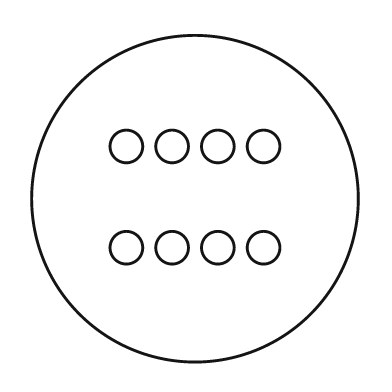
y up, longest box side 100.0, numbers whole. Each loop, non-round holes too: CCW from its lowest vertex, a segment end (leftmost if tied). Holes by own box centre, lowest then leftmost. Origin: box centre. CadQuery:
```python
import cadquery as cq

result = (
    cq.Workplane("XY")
    .moveTo(0.0, 0.0)
    .circle(50.0)
    .moveTo(-21.0, -15.0)
    .circle(5.0)
    .moveTo(-7.0, -15.0)
    .circle(5.0)
    .moveTo(7.0, -15.0)
    .circle(5.0)
    .moveTo(21.0, -15.0)
    .circle(5.0)
    .moveTo(-21.0, 16.0)
    .circle(5.0)
    .moveTo(-7.0, 16.0)
    .circle(5.0)
    .moveTo(7.0, 16.0)
    .circle(5.0)
    .moveTo(21.0, 16.0)
    .circle(5.0)
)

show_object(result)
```